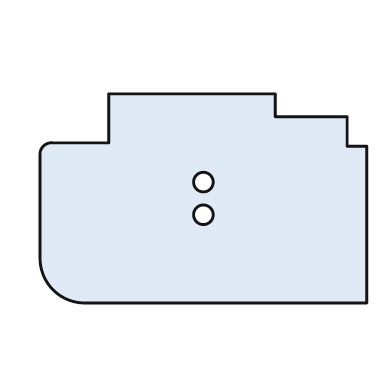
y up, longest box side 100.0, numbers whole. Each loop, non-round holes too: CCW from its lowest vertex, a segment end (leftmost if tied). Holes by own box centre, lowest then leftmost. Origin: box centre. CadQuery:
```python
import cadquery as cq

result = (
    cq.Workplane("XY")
    .moveTo(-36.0, -32.0)
    .lineTo(50.0, -32.0)
    .lineTo(50.0, 16.0)
    .lineTo(44.0, 16.0)
    .lineTo(44.0, 25.0)
    .lineTo(22.0, 25.0)
    .lineTo(22.0, 32.0)
    .lineTo(-29.0, 32.0)
    .lineTo(-29.0, 17.0)
    .lineTo(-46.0, 17.0)
    .threePointArc((-49.0, 16.0), (-50.0, 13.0))
    .lineTo(-50.0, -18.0)
    .threePointArc((-46.0, -28.0), (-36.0, -32.0))
    .close()
    .moveTo(0.0, -5.0)
    .circle(3.0)
    .moveTo(0.0, 5.0)
    .circle(3.0)
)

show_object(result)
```